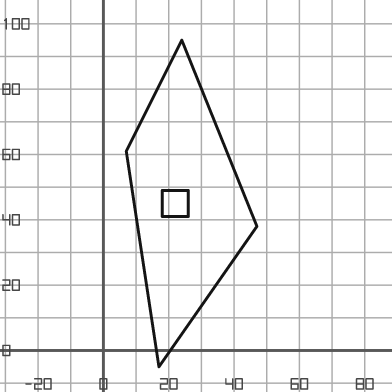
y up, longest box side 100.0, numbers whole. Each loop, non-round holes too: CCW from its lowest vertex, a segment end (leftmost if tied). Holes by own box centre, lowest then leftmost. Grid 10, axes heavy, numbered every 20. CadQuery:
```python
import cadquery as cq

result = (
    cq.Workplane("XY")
    .moveTo(17.0, -5.0)
    .lineTo(47.0, 38.0)
    .lineTo(24.0, 95.0)
    .lineTo(7.0, 61.0)
    .close()
    .moveTo(18.0, 41.0)
    .lineTo(26.0, 41.0)
    .lineTo(26.0, 49.0)
    .lineTo(18.0, 49.0)
    .close()
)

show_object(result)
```